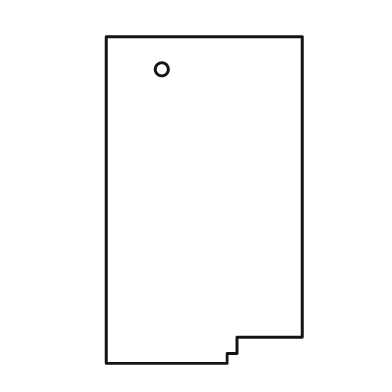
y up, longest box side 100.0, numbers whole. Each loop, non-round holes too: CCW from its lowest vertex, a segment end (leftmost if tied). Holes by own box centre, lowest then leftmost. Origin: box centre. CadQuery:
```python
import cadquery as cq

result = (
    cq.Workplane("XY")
    .moveTo(-30.0, -50.0)
    .lineTo(7.0, -50.0)
    .lineTo(7.0, -47.0)
    .lineTo(10.0, -47.0)
    .lineTo(10.0, -42.0)
    .lineTo(30.0, -42.0)
    .lineTo(30.0, 50.0)
    .lineTo(-30.0, 50.0)
    .close()
    .moveTo(-13.0, 40.0)
    .circle(2.0)
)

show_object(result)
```